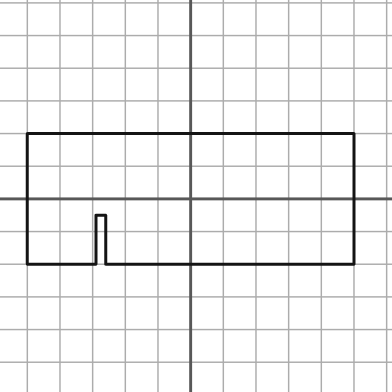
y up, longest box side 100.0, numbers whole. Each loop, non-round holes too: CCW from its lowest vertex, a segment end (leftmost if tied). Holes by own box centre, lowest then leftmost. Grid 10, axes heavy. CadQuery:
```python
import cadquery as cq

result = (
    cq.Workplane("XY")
    .moveTo(-50.0, -20.0)
    .lineTo(-29.0, -20.0)
    .lineTo(-29.0, -5.0)
    .lineTo(-26.0, -5.0)
    .lineTo(-26.0, -20.0)
    .lineTo(50.0, -20.0)
    .lineTo(50.0, 20.0)
    .lineTo(-50.0, 20.0)
    .close()
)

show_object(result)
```